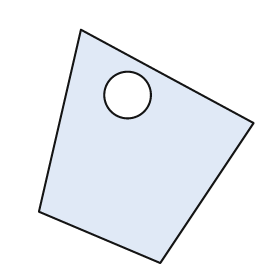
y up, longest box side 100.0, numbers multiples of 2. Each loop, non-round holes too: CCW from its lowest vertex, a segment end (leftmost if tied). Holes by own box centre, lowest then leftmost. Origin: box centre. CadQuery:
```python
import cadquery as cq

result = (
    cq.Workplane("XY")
    .moveTo(6.0, -50.0)
    .lineTo(46.0, 10.0)
    .lineTo(-28.0, 50.0)
    .lineTo(-46.0, -28.0)
    .close()
    .moveTo(-8.0, 22.0)
    .circle(10.0)
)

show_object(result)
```